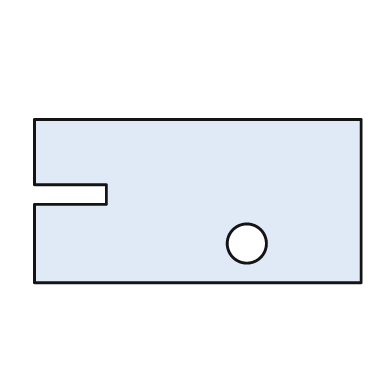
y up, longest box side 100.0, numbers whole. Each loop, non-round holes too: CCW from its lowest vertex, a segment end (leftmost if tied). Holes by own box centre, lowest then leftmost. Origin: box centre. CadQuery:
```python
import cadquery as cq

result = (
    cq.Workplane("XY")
    .moveTo(-50.0, -25.0)
    .lineTo(50.0, -25.0)
    .lineTo(50.0, 25.0)
    .lineTo(-50.0, 25.0)
    .lineTo(-50.0, 5.0)
    .lineTo(-28.0, 5.0)
    .lineTo(-28.0, -1.0)
    .lineTo(-50.0, -1.0)
    .close()
    .moveTo(15.0, -13.0)
    .circle(6.0)
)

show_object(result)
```